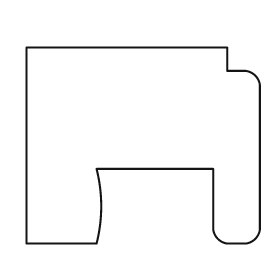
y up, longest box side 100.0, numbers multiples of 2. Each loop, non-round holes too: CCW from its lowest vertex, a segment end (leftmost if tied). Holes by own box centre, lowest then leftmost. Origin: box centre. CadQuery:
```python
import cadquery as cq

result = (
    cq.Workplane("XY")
    .moveTo(-50.0, -42.0)
    .lineTo(-20.0, -42.0)
    .threePointArc((-18.0, -26.0), (-20.0, -10.0))
    .lineTo(30.0, -10.0)
    .lineTo(30.0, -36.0)
    .threePointArc((32.0, -40.0), (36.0, -42.0))
    .lineTo(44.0, -42.0)
    .threePointArc((48.0, -40.0), (50.0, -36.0))
    .lineTo(50.0, 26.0)
    .threePointArc((48.0, 30.0), (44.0, 32.0))
    .lineTo(36.0, 32.0)
    .lineTo(36.0, 42.0)
    .lineTo(-50.0, 42.0)
    .close()
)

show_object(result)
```